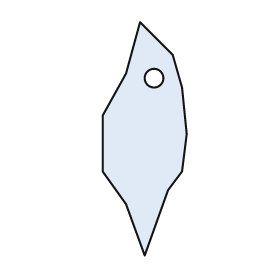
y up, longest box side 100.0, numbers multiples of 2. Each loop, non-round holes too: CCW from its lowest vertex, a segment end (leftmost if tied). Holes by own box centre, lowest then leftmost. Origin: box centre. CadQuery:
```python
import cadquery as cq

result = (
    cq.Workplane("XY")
    .moveTo(0.0, -50.0)
    .lineTo(10.0, -22.0)
    .lineTo(16.0, -14.0)
    .lineTo(18.0, 2.0)
    .lineTo(16.0, 22.0)
    .lineTo(12.0, 36.0)
    .lineTo(-2.0, 50.0)
    .lineTo(-8.0, 28.0)
    .lineTo(-18.0, 10.0)
    .lineTo(-18.0, -14.0)
    .lineTo(-8.0, -28.0)
    .close()
    .moveTo(4.0, 26.0)
    .circle(4.0)
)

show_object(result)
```